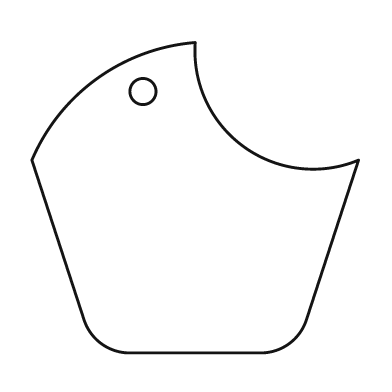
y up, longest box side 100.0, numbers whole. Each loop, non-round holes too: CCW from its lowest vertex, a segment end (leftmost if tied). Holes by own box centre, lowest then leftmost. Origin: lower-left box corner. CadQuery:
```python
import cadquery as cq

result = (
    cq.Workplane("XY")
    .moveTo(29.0, 0.0)
    .lineTo(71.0, 0.0)
    .threePointArc((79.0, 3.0), (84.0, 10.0))
    .lineTo(100.0, 59.0)
    .threePointArc((65.0, 63.0), (50.0, 95.0))
    .threePointArc((20.0, 84.0), (0.0, 59.0))
    .lineTo(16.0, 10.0)
    .threePointArc((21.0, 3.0), (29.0, 0.0))
    .close()
    .moveTo(34.0, 80.0)
    .circle(4.0)
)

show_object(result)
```